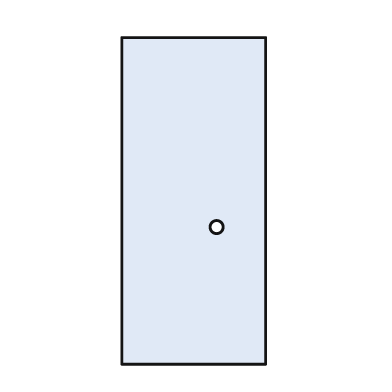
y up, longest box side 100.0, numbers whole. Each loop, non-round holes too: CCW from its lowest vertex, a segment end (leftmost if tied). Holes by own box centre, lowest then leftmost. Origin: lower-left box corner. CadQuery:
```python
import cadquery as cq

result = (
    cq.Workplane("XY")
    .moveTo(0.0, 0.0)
    .lineTo(44.0, 0.0)
    .lineTo(44.0, 100.0)
    .lineTo(0.0, 100.0)
    .close()
    .moveTo(29.0, 42.0)
    .circle(2.0)
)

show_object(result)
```